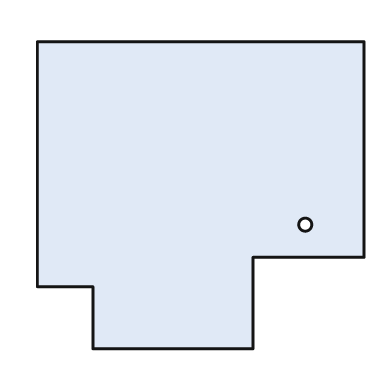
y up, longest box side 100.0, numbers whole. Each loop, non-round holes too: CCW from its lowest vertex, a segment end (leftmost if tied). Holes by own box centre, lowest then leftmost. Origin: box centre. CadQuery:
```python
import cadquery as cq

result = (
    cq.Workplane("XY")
    .moveTo(-33.0, -47.0)
    .lineTo(16.0, -47.0)
    .lineTo(16.0, -19.0)
    .lineTo(50.0, -19.0)
    .lineTo(50.0, 47.0)
    .lineTo(-50.0, 47.0)
    .lineTo(-50.0, -28.0)
    .lineTo(-33.0, -28.0)
    .close()
    .moveTo(32.0, -9.0)
    .circle(2.0)
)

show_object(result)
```